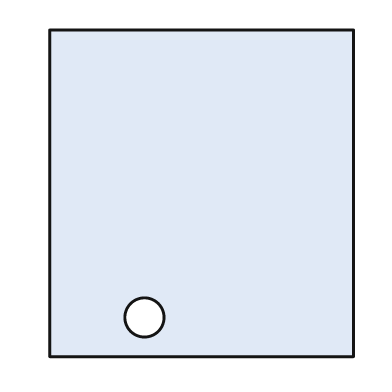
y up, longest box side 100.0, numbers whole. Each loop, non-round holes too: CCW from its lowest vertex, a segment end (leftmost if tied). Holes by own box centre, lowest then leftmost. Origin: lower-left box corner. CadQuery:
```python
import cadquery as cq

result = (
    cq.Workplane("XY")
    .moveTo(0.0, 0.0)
    .lineTo(93.0, 0.0)
    .lineTo(93.0, 100.0)
    .lineTo(0.0, 100.0)
    .close()
    .moveTo(29.0, 12.0)
    .circle(6.0)
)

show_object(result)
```